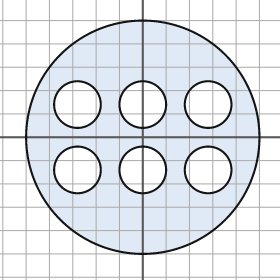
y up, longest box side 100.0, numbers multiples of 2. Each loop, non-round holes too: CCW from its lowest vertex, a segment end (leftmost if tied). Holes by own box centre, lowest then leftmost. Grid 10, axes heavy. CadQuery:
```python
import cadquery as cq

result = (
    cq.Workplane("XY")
    .moveTo(0.0, 0.0)
    .circle(50.0)
    .moveTo(-28.0, -14.0)
    .circle(10.0)
    .moveTo(0.0, -14.0)
    .circle(10.0)
    .moveTo(28.0, -14.0)
    .circle(10.0)
    .moveTo(-28.0, 14.0)
    .circle(10.0)
    .moveTo(0.0, 14.0)
    .circle(10.0)
    .moveTo(28.0, 14.0)
    .circle(10.0)
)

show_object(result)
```